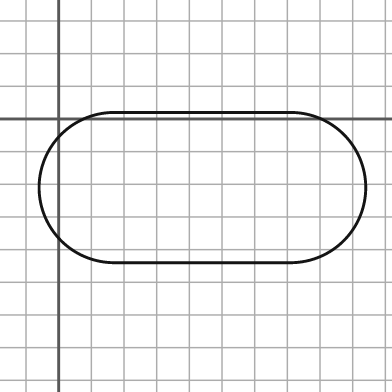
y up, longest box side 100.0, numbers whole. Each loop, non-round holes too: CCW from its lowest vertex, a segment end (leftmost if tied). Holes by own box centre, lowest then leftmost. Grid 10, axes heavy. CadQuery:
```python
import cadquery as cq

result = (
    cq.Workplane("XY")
    .moveTo(17.0, -44.0)
    .lineTo(71.0, -44.0)
    .threePointArc((94.0, -21.0), (71.0, 2.0))
    .lineTo(17.0, 2.0)
    .threePointArc((-6.0, -21.0), (17.0, -44.0))
    .close()
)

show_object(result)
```